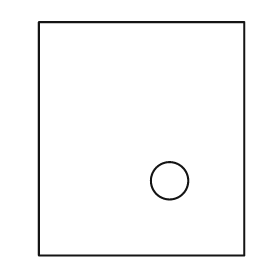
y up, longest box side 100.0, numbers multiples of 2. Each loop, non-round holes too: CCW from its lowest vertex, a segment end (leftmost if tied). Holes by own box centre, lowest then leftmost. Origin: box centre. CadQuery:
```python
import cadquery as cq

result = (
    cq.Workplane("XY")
    .moveTo(-44.0, -50.0)
    .lineTo(44.0, -50.0)
    .lineTo(44.0, 50.0)
    .lineTo(-44.0, 50.0)
    .close()
    .moveTo(12.0, -18.0)
    .circle(8.0)
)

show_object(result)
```